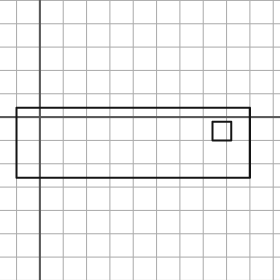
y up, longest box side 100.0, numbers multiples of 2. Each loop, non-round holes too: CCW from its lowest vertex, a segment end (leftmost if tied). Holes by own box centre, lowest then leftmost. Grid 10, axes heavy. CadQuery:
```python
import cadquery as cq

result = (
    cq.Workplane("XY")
    .moveTo(-10.0, -26.0)
    .lineTo(90.0, -26.0)
    .lineTo(90.0, 4.0)
    .lineTo(-10.0, 4.0)
    .close()
    .moveTo(74.0, -10.0)
    .lineTo(82.0, -10.0)
    .lineTo(82.0, -2.0)
    .lineTo(74.0, -2.0)
    .close()
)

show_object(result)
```